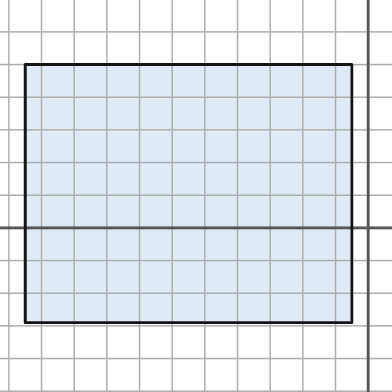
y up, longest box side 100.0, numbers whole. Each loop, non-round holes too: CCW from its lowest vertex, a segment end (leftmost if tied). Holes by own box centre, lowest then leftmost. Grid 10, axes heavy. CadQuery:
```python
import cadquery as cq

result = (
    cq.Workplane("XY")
    .moveTo(-105.0, -29.0)
    .lineTo(-5.0, -29.0)
    .lineTo(-5.0, 50.0)
    .lineTo(-105.0, 50.0)
    .close()
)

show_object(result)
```